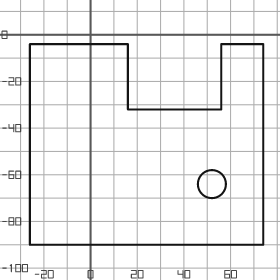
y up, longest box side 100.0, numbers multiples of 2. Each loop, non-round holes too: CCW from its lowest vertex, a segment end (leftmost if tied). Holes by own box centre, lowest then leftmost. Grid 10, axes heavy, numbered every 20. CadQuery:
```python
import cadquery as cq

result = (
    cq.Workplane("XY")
    .moveTo(-26.0, -90.0)
    .lineTo(74.0, -90.0)
    .lineTo(74.0, -4.0)
    .lineTo(56.0, -4.0)
    .lineTo(56.0, -32.0)
    .lineTo(16.0, -32.0)
    .lineTo(16.0, -4.0)
    .lineTo(-26.0, -4.0)
    .close()
    .moveTo(52.0, -64.0)
    .circle(6.0)
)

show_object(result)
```